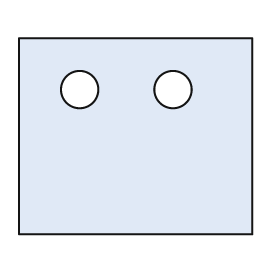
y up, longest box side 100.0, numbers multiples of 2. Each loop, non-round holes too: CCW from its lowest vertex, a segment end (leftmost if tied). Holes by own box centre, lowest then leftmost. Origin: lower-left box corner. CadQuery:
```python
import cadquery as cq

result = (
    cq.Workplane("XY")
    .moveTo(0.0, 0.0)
    .lineTo(100.0, 0.0)
    .lineTo(100.0, 84.0)
    .lineTo(0.0, 84.0)
    .close()
    .moveTo(26.0, 62.0)
    .circle(8.0)
    .moveTo(66.0, 62.0)
    .circle(8.0)
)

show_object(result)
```